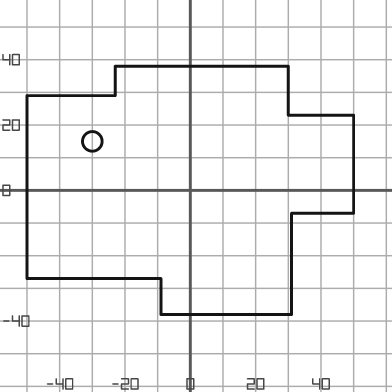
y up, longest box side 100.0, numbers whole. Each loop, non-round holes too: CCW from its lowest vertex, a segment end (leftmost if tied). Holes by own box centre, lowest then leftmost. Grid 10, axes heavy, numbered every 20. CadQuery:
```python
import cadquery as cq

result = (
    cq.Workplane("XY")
    .moveTo(-9.0, -38.0)
    .lineTo(31.0, -38.0)
    .lineTo(31.0, -7.0)
    .lineTo(50.0, -7.0)
    .lineTo(50.0, 23.0)
    .lineTo(30.0, 23.0)
    .lineTo(30.0, 38.0)
    .lineTo(-23.0, 38.0)
    .lineTo(-23.0, 29.0)
    .lineTo(-50.0, 29.0)
    .lineTo(-50.0, -27.0)
    .lineTo(-9.0, -27.0)
    .close()
    .moveTo(-30.0, 15.0)
    .circle(3.0)
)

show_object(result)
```